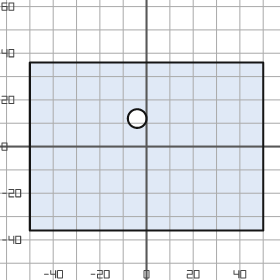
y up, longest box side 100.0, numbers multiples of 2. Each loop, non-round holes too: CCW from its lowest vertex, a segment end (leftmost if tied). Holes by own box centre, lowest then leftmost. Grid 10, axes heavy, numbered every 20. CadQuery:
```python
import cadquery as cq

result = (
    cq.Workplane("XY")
    .moveTo(-50.0, -36.0)
    .lineTo(50.0, -36.0)
    .lineTo(50.0, 36.0)
    .lineTo(-50.0, 36.0)
    .close()
    .moveTo(-4.0, 12.0)
    .circle(4.0)
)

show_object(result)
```